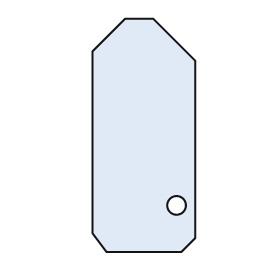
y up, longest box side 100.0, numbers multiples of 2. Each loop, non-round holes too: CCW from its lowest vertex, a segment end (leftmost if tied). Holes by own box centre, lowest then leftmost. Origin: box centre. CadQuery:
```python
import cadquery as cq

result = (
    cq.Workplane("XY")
    .moveTo(-16.0, -50.0)
    .lineTo(16.0, -50.0)
    .lineTo(22.0, -44.0)
    .lineTo(22.0, 32.0)
    .lineTo(4.0, 50.0)
    .lineTo(-8.0, 50.0)
    .lineTo(-22.0, 36.0)
    .lineTo(-22.0, -42.0)
    .close()
    .moveTo(14.0, -30.0)
    .circle(4.0)
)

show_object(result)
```